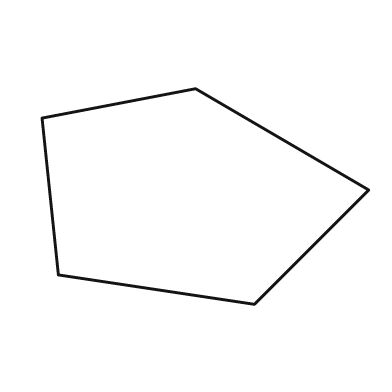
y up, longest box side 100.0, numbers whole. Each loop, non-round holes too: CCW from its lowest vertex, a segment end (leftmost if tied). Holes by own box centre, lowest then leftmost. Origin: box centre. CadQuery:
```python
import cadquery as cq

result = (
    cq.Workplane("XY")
    .moveTo(15.0, -33.0)
    .lineTo(50.0, 2.0)
    .lineTo(-3.0, 33.0)
    .lineTo(-50.0, 24.0)
    .lineTo(-45.0, -24.0)
    .close()
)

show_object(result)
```